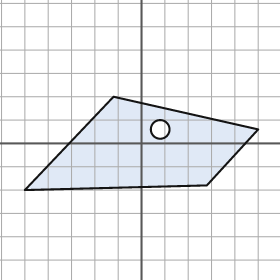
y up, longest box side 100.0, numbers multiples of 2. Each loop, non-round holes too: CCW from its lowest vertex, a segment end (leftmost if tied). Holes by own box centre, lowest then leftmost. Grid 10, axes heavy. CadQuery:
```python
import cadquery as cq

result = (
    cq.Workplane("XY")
    .moveTo(-50.0, -20.0)
    .lineTo(28.0, -18.0)
    .lineTo(50.0, 6.0)
    .lineTo(-12.0, 20.0)
    .close()
    .moveTo(8.0, 6.0)
    .circle(4.0)
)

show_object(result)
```